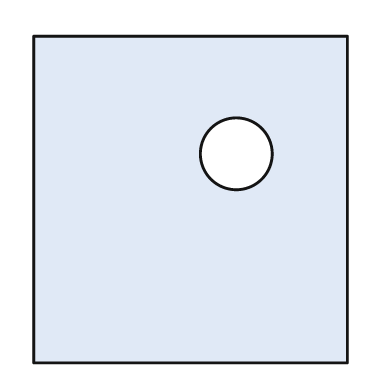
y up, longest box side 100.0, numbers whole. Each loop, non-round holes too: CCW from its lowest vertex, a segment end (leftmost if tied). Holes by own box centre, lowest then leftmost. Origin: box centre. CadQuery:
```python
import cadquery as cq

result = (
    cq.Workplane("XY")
    .moveTo(-48.0, -50.0)
    .lineTo(48.0, -50.0)
    .lineTo(48.0, 50.0)
    .lineTo(-48.0, 50.0)
    .close()
    .moveTo(14.0, 14.0)
    .circle(11.0)
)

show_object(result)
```